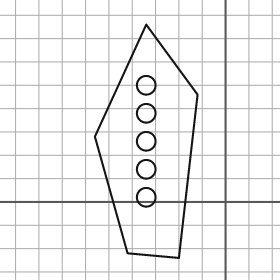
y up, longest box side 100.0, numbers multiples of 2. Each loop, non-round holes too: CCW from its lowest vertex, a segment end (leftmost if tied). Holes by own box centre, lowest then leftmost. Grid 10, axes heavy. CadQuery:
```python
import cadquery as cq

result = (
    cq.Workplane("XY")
    .moveTo(-20.0, -24.0)
    .lineTo(-12.0, 46.0)
    .lineTo(-34.0, 76.0)
    .lineTo(-56.0, 28.0)
    .lineTo(-42.0, -22.0)
    .close()
    .moveTo(-34.0, 2.0)
    .circle(4.0)
    .moveTo(-34.0, 14.0)
    .circle(4.0)
    .moveTo(-34.0, 26.0)
    .circle(4.0)
    .moveTo(-34.0, 38.0)
    .circle(4.0)
    .moveTo(-34.0, 50.0)
    .circle(4.0)
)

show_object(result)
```